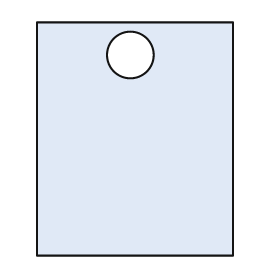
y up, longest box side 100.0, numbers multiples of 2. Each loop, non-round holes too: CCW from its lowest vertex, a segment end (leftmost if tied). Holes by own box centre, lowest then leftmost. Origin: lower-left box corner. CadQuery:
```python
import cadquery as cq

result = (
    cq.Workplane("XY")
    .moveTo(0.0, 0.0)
    .lineTo(84.0, 0.0)
    .lineTo(84.0, 100.0)
    .lineTo(0.0, 100.0)
    .close()
    .moveTo(40.0, 86.0)
    .circle(10.0)
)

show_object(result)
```